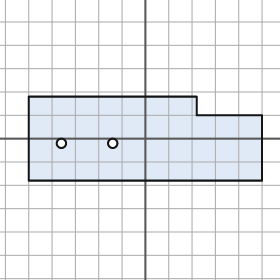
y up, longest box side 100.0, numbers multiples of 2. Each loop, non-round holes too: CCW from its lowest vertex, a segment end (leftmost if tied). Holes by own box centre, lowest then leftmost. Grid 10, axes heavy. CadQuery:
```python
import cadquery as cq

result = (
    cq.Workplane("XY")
    .moveTo(-50.0, -18.0)
    .lineTo(50.0, -18.0)
    .lineTo(50.0, 10.0)
    .lineTo(22.0, 10.0)
    .lineTo(22.0, 18.0)
    .lineTo(-50.0, 18.0)
    .close()
    .moveTo(-36.0, -2.0)
    .circle(2.0)
    .moveTo(-14.0, -2.0)
    .circle(2.0)
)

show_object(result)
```